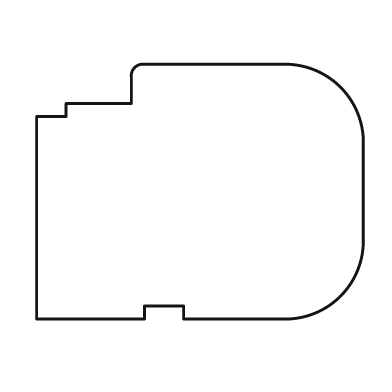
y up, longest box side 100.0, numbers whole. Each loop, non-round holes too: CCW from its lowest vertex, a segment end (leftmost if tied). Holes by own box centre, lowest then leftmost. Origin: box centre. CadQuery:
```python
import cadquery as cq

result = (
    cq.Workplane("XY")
    .moveTo(-50.0, -39.0)
    .lineTo(-17.0, -39.0)
    .lineTo(-17.0, -35.0)
    .lineTo(-5.0, -35.0)
    .lineTo(-5.0, -39.0)
    .lineTo(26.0, -39.0)
    .threePointArc((43.0, -32.0), (50.0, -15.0))
    .lineTo(50.0, 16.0)
    .threePointArc((43.0, 32.0), (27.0, 39.0))
    .lineTo(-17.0, 39.0)
    .threePointArc((-20.0, 38.0), (-21.0, 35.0))
    .lineTo(-21.0, 27.0)
    .lineTo(-41.0, 27.0)
    .lineTo(-41.0, 23.0)
    .lineTo(-50.0, 23.0)
    .close()
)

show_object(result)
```